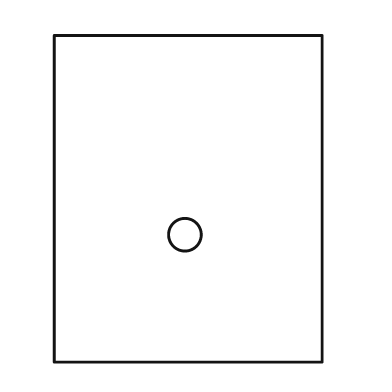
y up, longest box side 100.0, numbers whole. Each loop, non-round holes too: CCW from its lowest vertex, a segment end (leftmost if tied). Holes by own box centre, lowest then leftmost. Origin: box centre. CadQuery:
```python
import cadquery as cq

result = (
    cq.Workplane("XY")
    .moveTo(-41.0, -50.0)
    .lineTo(41.0, -50.0)
    .lineTo(41.0, 50.0)
    .lineTo(-41.0, 50.0)
    .close()
    .moveTo(-1.0, -11.0)
    .circle(5.0)
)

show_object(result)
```